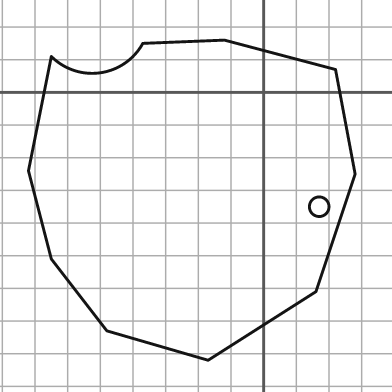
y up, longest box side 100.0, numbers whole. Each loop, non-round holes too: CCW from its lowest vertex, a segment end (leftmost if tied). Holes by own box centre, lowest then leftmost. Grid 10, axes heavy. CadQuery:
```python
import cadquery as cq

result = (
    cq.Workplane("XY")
    .moveTo(-17.0, -82.0)
    .lineTo(16.0, -61.0)
    .lineTo(28.0, -25.0)
    .lineTo(22.0, 7.0)
    .lineTo(-12.0, 16.0)
    .lineTo(-37.0, 15.0)
    .threePointArc((-50.0, 6.0), (-65.0, 11.0))
    .lineTo(-72.0, -24.0)
    .lineTo(-65.0, -51.0)
    .lineTo(-48.0, -73.0)
    .close()
    .moveTo(17.0, -35.0)
    .circle(3.0)
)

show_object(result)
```